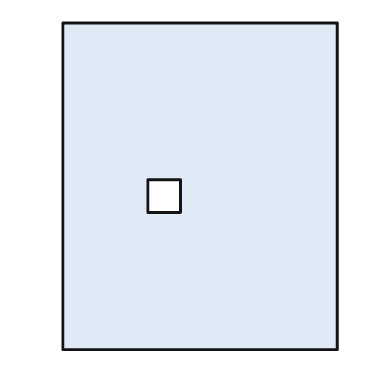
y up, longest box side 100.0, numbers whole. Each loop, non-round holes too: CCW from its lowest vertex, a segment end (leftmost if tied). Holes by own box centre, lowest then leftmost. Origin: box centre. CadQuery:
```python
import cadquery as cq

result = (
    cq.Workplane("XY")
    .moveTo(-42.0, -50.0)
    .lineTo(42.0, -50.0)
    .lineTo(42.0, 50.0)
    .lineTo(-42.0, 50.0)
    .close()
    .moveTo(-16.0, -8.0)
    .lineTo(-6.0, -8.0)
    .lineTo(-6.0, 2.0)
    .lineTo(-16.0, 2.0)
    .close()
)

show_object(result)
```